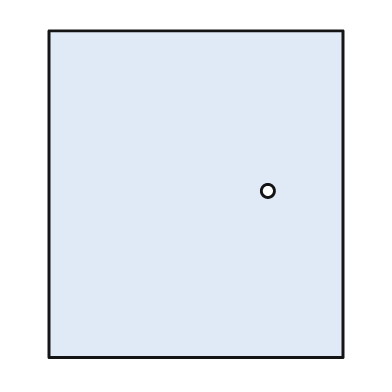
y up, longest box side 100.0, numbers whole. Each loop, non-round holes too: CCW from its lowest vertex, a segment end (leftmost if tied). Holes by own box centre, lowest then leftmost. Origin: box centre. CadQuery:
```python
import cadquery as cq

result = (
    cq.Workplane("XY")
    .moveTo(-45.0, -50.0)
    .lineTo(45.0, -50.0)
    .lineTo(45.0, 50.0)
    .lineTo(-45.0, 50.0)
    .close()
    .moveTo(22.0, 1.0)
    .circle(2.0)
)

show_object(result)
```